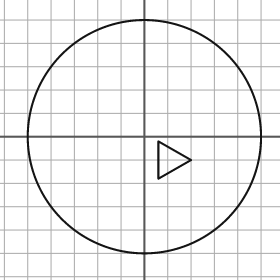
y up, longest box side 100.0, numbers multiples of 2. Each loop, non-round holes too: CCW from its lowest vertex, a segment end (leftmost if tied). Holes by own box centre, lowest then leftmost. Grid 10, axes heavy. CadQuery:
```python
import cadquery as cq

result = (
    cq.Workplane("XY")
    .moveTo(0.0, 0.0)
    .circle(50.0)
    .moveTo(6.0, -18.0)
    .lineTo(20.0, -10.0)
    .lineTo(6.0, -2.0)
    .close()
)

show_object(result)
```